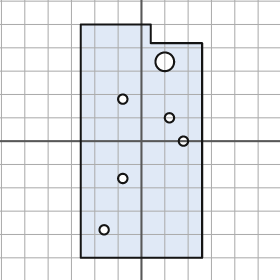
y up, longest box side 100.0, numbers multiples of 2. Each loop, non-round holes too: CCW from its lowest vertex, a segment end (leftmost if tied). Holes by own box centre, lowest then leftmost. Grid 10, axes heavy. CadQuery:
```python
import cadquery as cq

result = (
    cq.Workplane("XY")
    .moveTo(-26.0, -50.0)
    .lineTo(26.0, -50.0)
    .lineTo(26.0, 42.0)
    .lineTo(4.0, 42.0)
    .lineTo(4.0, 50.0)
    .lineTo(-26.0, 50.0)
    .close()
    .moveTo(-16.0, -38.0)
    .circle(2.0)
    .moveTo(-8.0, -16.0)
    .circle(2.0)
    .moveTo(18.0, 0.0)
    .circle(2.0)
    .moveTo(12.0, 10.0)
    .circle(2.0)
    .moveTo(-8.0, 18.0)
    .circle(2.0)
    .moveTo(10.0, 34.0)
    .circle(4.0)
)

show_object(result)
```